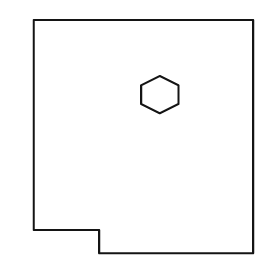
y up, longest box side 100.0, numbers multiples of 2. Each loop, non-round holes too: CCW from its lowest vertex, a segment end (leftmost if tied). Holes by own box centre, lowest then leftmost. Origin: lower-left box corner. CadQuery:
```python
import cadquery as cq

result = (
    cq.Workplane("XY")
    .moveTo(28.0, 0.0)
    .lineTo(94.0, 0.0)
    .lineTo(94.0, 100.0)
    .lineTo(0.0, 100.0)
    .lineTo(0.0, 10.0)
    .lineTo(28.0, 10.0)
    .close()
    .moveTo(54.0, 60.0)
    .lineTo(62.0, 64.0)
    .lineTo(62.0, 72.0)
    .lineTo(54.0, 76.0)
    .lineTo(46.0, 72.0)
    .lineTo(46.0, 64.0)
    .close()
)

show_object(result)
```